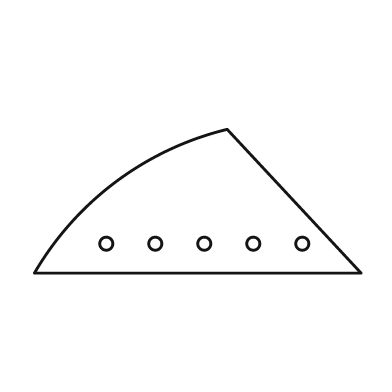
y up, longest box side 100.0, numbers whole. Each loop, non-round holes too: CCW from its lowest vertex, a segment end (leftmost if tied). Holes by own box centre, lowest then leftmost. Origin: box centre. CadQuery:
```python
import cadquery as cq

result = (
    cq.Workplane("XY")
    .moveTo(-50.0, -22.0)
    .lineTo(50.0, -22.0)
    .lineTo(9.0, 22.0)
    .threePointArc((-25.0, 6.0), (-50.0, -22.0))
    .close()
    .moveTo(-28.0, -13.0)
    .circle(2.0)
    .moveTo(-13.0, -13.0)
    .circle(2.0)
    .moveTo(2.0, -13.0)
    .circle(2.0)
    .moveTo(17.0, -13.0)
    .circle(2.0)
    .moveTo(32.0, -13.0)
    .circle(2.0)
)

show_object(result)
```